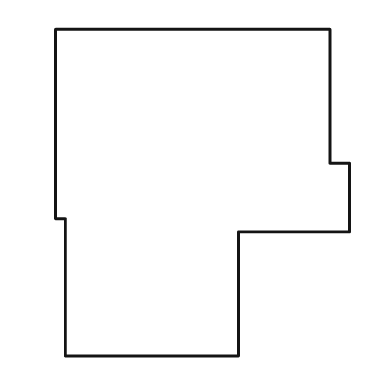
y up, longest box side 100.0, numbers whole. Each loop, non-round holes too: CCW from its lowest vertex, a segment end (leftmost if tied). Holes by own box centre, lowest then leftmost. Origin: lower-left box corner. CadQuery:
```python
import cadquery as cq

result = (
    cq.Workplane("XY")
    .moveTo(3.0, 0.0)
    .lineTo(56.0, 0.0)
    .lineTo(56.0, 38.0)
    .lineTo(90.0, 38.0)
    .lineTo(90.0, 59.0)
    .lineTo(84.0, 59.0)
    .lineTo(84.0, 100.0)
    .lineTo(0.0, 100.0)
    .lineTo(0.0, 42.0)
    .lineTo(3.0, 42.0)
    .close()
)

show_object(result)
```